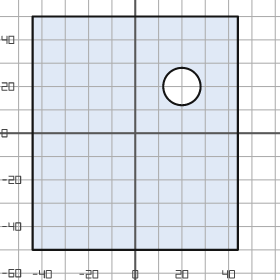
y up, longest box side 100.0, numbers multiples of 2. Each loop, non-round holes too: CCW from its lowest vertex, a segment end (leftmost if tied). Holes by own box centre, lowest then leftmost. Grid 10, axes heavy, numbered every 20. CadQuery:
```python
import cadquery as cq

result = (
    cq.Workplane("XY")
    .moveTo(-44.0, -50.0)
    .lineTo(44.0, -50.0)
    .lineTo(44.0, 50.0)
    .lineTo(-44.0, 50.0)
    .close()
    .moveTo(20.0, 20.0)
    .circle(8.0)
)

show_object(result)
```